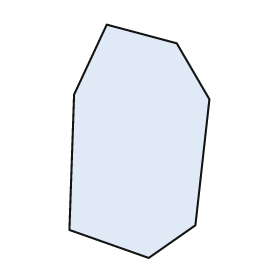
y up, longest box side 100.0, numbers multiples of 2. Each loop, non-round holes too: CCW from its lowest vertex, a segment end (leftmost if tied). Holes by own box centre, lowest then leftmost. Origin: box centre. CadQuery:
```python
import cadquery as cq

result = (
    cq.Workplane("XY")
    .moveTo(4.0, -50.0)
    .lineTo(24.0, -36.0)
    .lineTo(30.0, 18.0)
    .lineTo(16.0, 42.0)
    .lineTo(-14.0, 50.0)
    .lineTo(-28.0, 20.0)
    .lineTo(-30.0, -38.0)
    .close()
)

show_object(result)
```